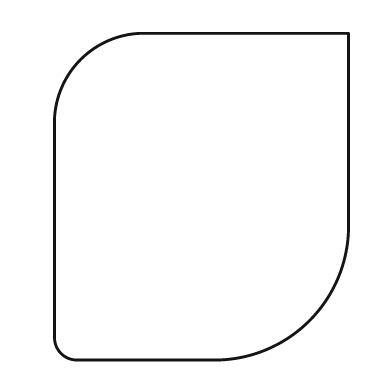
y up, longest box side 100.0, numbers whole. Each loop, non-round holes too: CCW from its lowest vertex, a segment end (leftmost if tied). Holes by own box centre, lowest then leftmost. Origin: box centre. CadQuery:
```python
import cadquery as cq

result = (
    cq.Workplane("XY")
    .moveTo(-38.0, -50.0)
    .lineTo(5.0, -50.0)
    .threePointArc((33.0, -38.0), (45.0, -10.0))
    .lineTo(45.0, 50.0)
    .lineTo(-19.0, 50.0)
    .threePointArc((-37.0, 42.0), (-45.0, 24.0))
    .lineTo(-45.0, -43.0)
    .threePointArc((-43.0, -48.0), (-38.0, -50.0))
    .close()
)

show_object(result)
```